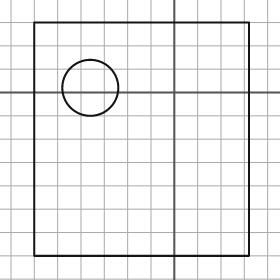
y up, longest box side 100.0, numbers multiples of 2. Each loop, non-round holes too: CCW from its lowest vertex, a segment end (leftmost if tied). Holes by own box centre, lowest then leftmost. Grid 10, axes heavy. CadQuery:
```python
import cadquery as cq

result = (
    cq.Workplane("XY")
    .moveTo(-60.0, -70.0)
    .lineTo(32.0, -70.0)
    .lineTo(32.0, 30.0)
    .lineTo(-60.0, 30.0)
    .close()
    .moveTo(-36.0, 2.0)
    .circle(12.0)
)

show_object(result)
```